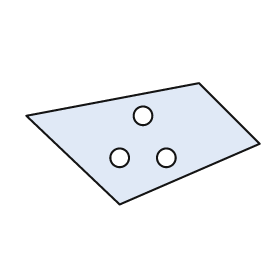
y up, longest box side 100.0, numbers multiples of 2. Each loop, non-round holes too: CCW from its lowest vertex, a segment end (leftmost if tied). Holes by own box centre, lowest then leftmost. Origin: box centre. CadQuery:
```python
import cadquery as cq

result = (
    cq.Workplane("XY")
    .moveTo(-10.0, -26.0)
    .lineTo(50.0, 0.0)
    .lineTo(24.0, 26.0)
    .lineTo(-50.0, 12.0)
    .close()
    .moveTo(-10.0, -6.0)
    .circle(4.0)
    .moveTo(10.0, -6.0)
    .circle(4.0)
    .moveTo(0.0, 12.0)
    .circle(4.0)
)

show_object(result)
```